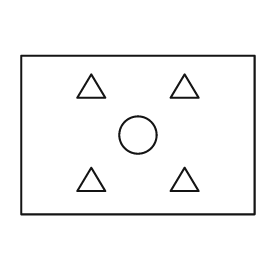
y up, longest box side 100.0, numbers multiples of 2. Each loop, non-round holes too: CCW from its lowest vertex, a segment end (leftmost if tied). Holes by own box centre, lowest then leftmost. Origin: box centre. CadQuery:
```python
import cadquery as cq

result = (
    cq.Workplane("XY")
    .moveTo(-50.0, -34.0)
    .lineTo(50.0, -34.0)
    .lineTo(50.0, 34.0)
    .lineTo(-50.0, 34.0)
    .close()
    .moveTo(-26.0, -24.0)
    .lineTo(-14.0, -24.0)
    .lineTo(-20.0, -14.0)
    .close()
    .moveTo(14.0, -24.0)
    .lineTo(26.0, -24.0)
    .lineTo(20.0, -14.0)
    .close()
    .moveTo(0.0, 0.0)
    .circle(8.0)
    .moveTo(-26.0, 16.0)
    .lineTo(-14.0, 16.0)
    .lineTo(-20.0, 26.0)
    .close()
    .moveTo(14.0, 16.0)
    .lineTo(26.0, 16.0)
    .lineTo(20.0, 26.0)
    .close()
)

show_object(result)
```